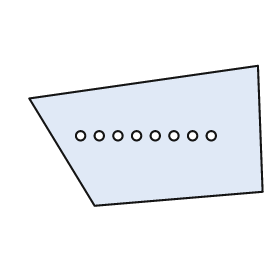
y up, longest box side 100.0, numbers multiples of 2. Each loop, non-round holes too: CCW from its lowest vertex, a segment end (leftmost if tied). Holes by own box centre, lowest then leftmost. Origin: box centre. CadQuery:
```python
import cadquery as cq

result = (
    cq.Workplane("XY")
    .moveTo(-22.0, -30.0)
    .lineTo(50.0, -24.0)
    .lineTo(48.0, 30.0)
    .lineTo(-50.0, 16.0)
    .close()
    .moveTo(-28.0, 0.0)
    .circle(2.0)
    .moveTo(-20.0, 0.0)
    .circle(2.0)
    .moveTo(-12.0, 0.0)
    .circle(2.0)
    .moveTo(-4.0, 0.0)
    .circle(2.0)
    .moveTo(4.0, 0.0)
    .circle(2.0)
    .moveTo(12.0, 0.0)
    .circle(2.0)
    .moveTo(20.0, 0.0)
    .circle(2.0)
    .moveTo(28.0, 0.0)
    .circle(2.0)
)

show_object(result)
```